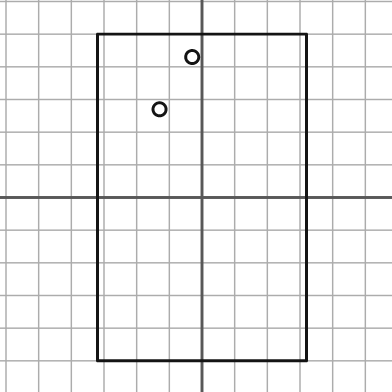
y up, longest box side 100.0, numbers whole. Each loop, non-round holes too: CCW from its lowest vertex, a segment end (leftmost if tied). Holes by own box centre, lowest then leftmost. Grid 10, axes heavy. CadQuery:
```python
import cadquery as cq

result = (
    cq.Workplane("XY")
    .moveTo(-32.0, -50.0)
    .lineTo(32.0, -50.0)
    .lineTo(32.0, 50.0)
    .lineTo(-32.0, 50.0)
    .close()
    .moveTo(-13.0, 27.0)
    .circle(2.0)
    .moveTo(-3.0, 43.0)
    .circle(2.0)
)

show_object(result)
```